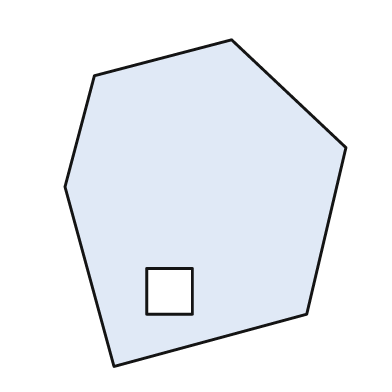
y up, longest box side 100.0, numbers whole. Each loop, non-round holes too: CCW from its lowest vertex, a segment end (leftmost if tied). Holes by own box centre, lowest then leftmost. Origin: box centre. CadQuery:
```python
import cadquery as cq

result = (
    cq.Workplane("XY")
    .moveTo(-28.0, -50.0)
    .lineTo(31.0, -34.0)
    .lineTo(43.0, 17.0)
    .lineTo(8.0, 50.0)
    .lineTo(-34.0, 39.0)
    .lineTo(-43.0, 5.0)
    .close()
    .moveTo(-18.0, -34.0)
    .lineTo(-4.0, -34.0)
    .lineTo(-4.0, -20.0)
    .lineTo(-18.0, -20.0)
    .close()
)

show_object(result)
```